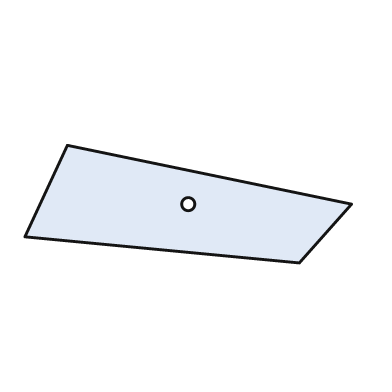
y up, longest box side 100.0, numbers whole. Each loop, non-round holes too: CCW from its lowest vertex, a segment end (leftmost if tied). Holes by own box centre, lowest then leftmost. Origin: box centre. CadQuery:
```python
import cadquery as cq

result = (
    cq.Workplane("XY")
    .moveTo(34.0, -18.0)
    .lineTo(50.0, 0.0)
    .lineTo(-37.0, 18.0)
    .lineTo(-50.0, -10.0)
    .close()
    .moveTo(0.0, 0.0)
    .circle(2.0)
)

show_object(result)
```